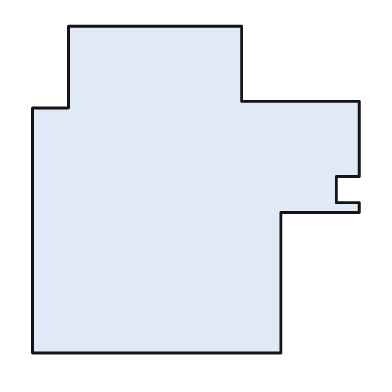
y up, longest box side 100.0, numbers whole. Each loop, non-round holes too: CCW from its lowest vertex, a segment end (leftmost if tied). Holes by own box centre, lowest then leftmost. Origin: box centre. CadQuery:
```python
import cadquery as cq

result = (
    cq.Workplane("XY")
    .moveTo(-50.0, -50.0)
    .lineTo(26.0, -50.0)
    .lineTo(26.0, -7.0)
    .lineTo(50.0, -7.0)
    .lineTo(50.0, -4.0)
    .lineTo(43.0, -4.0)
    .lineTo(43.0, 4.0)
    .lineTo(50.0, 4.0)
    .lineTo(50.0, 27.0)
    .lineTo(14.0, 27.0)
    .lineTo(14.0, 50.0)
    .lineTo(-39.0, 50.0)
    .lineTo(-39.0, 25.0)
    .lineTo(-50.0, 25.0)
    .close()
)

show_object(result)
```